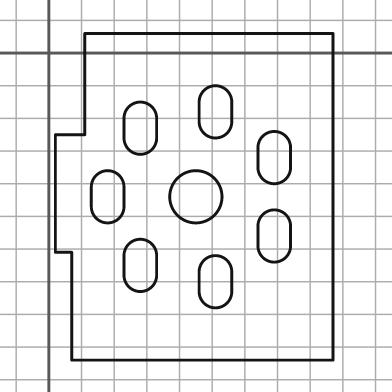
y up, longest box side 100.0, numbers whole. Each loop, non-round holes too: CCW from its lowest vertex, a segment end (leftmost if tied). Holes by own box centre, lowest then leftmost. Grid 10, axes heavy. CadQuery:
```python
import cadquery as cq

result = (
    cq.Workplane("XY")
    .moveTo(7.0, -94.0)
    .lineTo(87.0, -94.0)
    .lineTo(87.0, 6.0)
    .lineTo(11.0, 6.0)
    .lineTo(11.0, -25.0)
    .lineTo(2.0, -25.0)
    .lineTo(2.0, -61.0)
    .lineTo(7.0, -61.0)
    .close()
    .moveTo(46.0, -73.0)
    .threePointArc((51.0, -78.0), (56.0, -73.0))
    .lineTo(56.0, -67.0)
    .threePointArc((51.0, -62.0), (46.0, -67.0))
    .close()
    .moveTo(23.0, -68.0)
    .threePointArc((28.0, -73.0), (33.0, -68.0))
    .lineTo(33.0, -62.0)
    .threePointArc((28.0, -57.0), (23.0, -62.0))
    .close()
    .moveTo(64.0, -59.0)
    .threePointArc((69.0, -64.0), (74.0, -59.0))
    .lineTo(74.0, -53.0)
    .threePointArc((69.0, -48.0), (64.0, -53.0))
    .close()
    .moveTo(13.0, -47.0)
    .threePointArc((18.0, -52.0), (23.0, -47.0))
    .lineTo(23.0, -41.0)
    .threePointArc((18.0, -36.0), (13.0, -41.0))
    .close()
    .moveTo(45.0, -44.0)
    .circle(8.0)
    .moveTo(64.0, -35.0)
    .threePointArc((69.0, -40.0), (74.0, -35.0))
    .lineTo(74.0, -29.0)
    .threePointArc((69.0, -24.0), (64.0, -29.0))
    .close()
    .moveTo(23.0, -26.0)
    .threePointArc((28.0, -31.0), (33.0, -26.0))
    .lineTo(33.0, -20.0)
    .threePointArc((28.0, -15.0), (23.0, -20.0))
    .close()
    .moveTo(46.0, -21.0)
    .threePointArc((51.0, -26.0), (56.0, -21.0))
    .lineTo(56.0, -15.0)
    .threePointArc((51.0, -10.0), (46.0, -15.0))
    .close()
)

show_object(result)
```